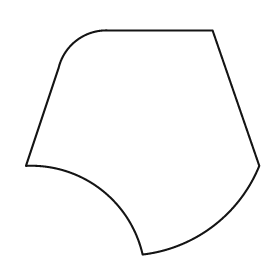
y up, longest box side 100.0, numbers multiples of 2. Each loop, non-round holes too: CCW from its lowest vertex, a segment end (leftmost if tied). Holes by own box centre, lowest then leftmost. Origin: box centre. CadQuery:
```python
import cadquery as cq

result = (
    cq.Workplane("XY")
    .moveTo(0.0, -48.0)
    .threePointArc((30.0, -36.0), (50.0, -10.0))
    .lineTo(30.0, 48.0)
    .lineTo(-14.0, 48.0)
    .threePointArc((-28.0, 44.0), (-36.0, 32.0))
    .lineTo(-50.0, -10.0)
    .threePointArc((-18.0, -20.0), (0.0, -48.0))
    .close()
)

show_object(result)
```